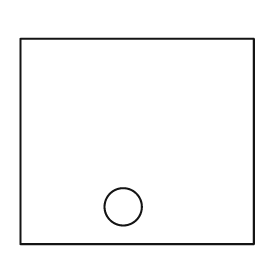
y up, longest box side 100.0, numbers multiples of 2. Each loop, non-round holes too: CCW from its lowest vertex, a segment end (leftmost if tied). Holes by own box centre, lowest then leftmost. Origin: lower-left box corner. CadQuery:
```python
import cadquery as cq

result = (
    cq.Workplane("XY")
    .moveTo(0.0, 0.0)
    .lineTo(100.0, 0.0)
    .lineTo(100.0, 88.0)
    .lineTo(0.0, 88.0)
    .close()
    .moveTo(44.0, 16.0)
    .circle(8.0)
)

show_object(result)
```